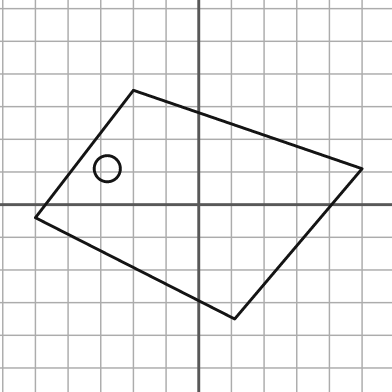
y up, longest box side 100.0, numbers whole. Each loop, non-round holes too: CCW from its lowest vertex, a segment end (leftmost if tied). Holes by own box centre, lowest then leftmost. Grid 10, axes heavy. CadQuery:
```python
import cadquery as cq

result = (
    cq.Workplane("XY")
    .moveTo(11.0, -35.0)
    .lineTo(50.0, 11.0)
    .lineTo(-20.0, 35.0)
    .lineTo(-50.0, -4.0)
    .close()
    .moveTo(-28.0, 11.0)
    .circle(4.0)
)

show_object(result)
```